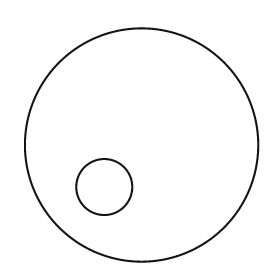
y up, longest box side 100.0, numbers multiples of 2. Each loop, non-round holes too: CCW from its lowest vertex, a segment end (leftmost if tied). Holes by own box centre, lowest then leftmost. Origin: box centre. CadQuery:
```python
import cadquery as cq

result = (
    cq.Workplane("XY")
    .moveTo(0.0, 0.0)
    .circle(50.0)
    .moveTo(-16.0, -18.0)
    .circle(12.0)
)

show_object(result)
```